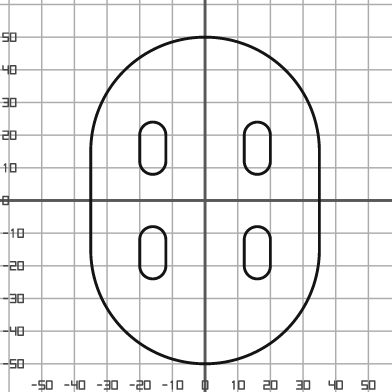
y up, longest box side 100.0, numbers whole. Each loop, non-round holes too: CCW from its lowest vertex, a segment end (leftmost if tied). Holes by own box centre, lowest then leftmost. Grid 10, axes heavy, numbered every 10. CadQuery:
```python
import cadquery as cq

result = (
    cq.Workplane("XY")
    .moveTo(-35.0, -15.0)
    .threePointArc((0.0, -50.0), (35.0, -15.0))
    .lineTo(35.0, 15.0)
    .threePointArc((0.0, 50.0), (-35.0, 15.0))
    .close()
    .moveTo(-20.0, -20.0)
    .threePointArc((-16.0, -24.0), (-12.0, -20.0))
    .lineTo(-12.0, -12.0)
    .threePointArc((-16.0, -8.0), (-20.0, -12.0))
    .close()
    .moveTo(12.0, -20.0)
    .threePointArc((16.0, -24.0), (20.0, -20.0))
    .lineTo(20.0, -12.0)
    .threePointArc((16.0, -8.0), (12.0, -12.0))
    .close()
    .moveTo(-20.0, 12.0)
    .threePointArc((-16.0, 8.0), (-12.0, 12.0))
    .lineTo(-12.0, 20.0)
    .threePointArc((-16.0, 24.0), (-20.0, 20.0))
    .close()
    .moveTo(12.0, 12.0)
    .threePointArc((16.0, 8.0), (20.0, 12.0))
    .lineTo(20.0, 20.0)
    .threePointArc((16.0, 24.0), (12.0, 20.0))
    .close()
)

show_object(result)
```